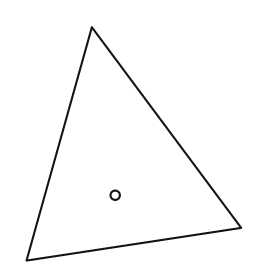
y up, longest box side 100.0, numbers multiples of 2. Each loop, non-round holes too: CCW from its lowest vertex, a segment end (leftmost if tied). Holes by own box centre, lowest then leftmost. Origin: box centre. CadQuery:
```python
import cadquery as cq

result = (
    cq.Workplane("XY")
    .moveTo(-46.0, -50.0)
    .lineTo(46.0, -36.0)
    .lineTo(-18.0, 50.0)
    .close()
    .moveTo(-8.0, -22.0)
    .circle(2.0)
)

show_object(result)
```